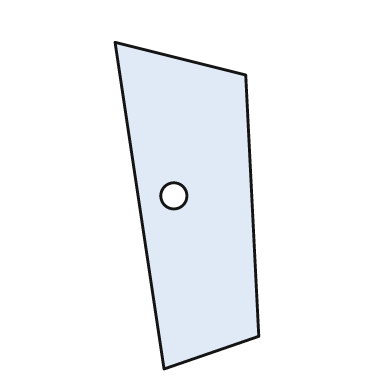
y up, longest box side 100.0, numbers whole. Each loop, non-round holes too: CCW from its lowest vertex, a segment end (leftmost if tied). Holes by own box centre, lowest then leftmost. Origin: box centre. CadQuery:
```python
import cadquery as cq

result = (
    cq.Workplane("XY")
    .moveTo(-7.0, -50.0)
    .lineTo(22.0, -40.0)
    .lineTo(18.0, 40.0)
    .lineTo(-22.0, 50.0)
    .close()
    .moveTo(-4.0, 3.0)
    .circle(4.0)
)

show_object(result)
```